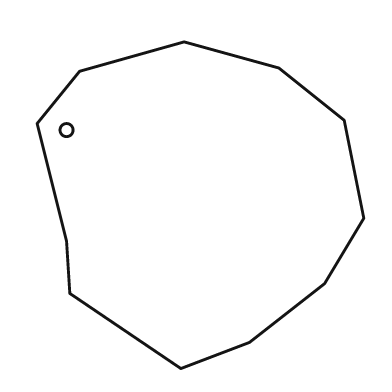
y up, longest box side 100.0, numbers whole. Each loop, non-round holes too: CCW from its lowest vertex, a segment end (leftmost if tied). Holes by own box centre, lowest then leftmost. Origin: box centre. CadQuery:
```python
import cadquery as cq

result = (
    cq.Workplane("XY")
    .moveTo(-6.0, -50.0)
    .lineTo(15.0, -42.0)
    .lineTo(38.0, -24.0)
    .lineTo(50.0, -4.0)
    .lineTo(44.0, 26.0)
    .lineTo(24.0, 42.0)
    .lineTo(-5.0, 50.0)
    .lineTo(-37.0, 41.0)
    .lineTo(-50.0, 25.0)
    .lineTo(-41.0, -11.0)
    .lineTo(-40.0, -27.0)
    .close()
    .moveTo(-41.0, 23.0)
    .circle(2.0)
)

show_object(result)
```